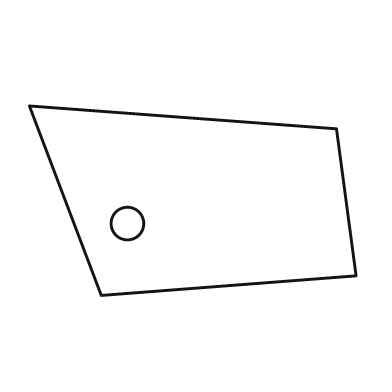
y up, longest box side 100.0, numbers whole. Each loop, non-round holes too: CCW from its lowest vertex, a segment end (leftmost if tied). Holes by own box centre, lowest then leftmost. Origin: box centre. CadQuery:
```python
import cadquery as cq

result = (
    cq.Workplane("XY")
    .moveTo(-28.0, -29.0)
    .lineTo(50.0, -23.0)
    .lineTo(44.0, 22.0)
    .lineTo(-50.0, 29.0)
    .close()
    .moveTo(-20.0, -7.0)
    .circle(5.0)
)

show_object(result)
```